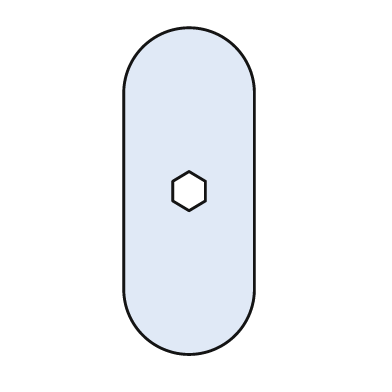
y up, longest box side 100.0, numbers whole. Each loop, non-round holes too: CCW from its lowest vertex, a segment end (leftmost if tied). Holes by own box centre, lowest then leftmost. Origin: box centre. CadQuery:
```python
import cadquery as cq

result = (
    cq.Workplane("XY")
    .moveTo(-20.0, -30.0)
    .threePointArc((0.0, -50.0), (20.0, -30.0))
    .lineTo(20.0, 30.0)
    .threePointArc((0.0, 50.0), (-20.0, 30.0))
    .close()
    .moveTo(0.0, -6.0)
    .lineTo(5.0, -3.0)
    .lineTo(5.0, 3.0)
    .lineTo(0.0, 6.0)
    .lineTo(-5.0, 3.0)
    .lineTo(-5.0, -3.0)
    .close()
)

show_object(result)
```